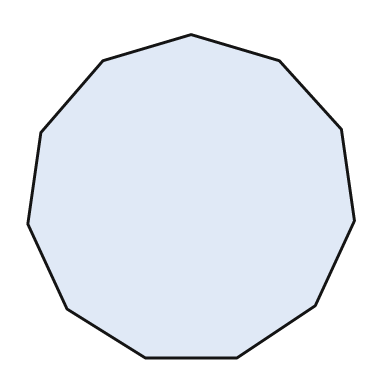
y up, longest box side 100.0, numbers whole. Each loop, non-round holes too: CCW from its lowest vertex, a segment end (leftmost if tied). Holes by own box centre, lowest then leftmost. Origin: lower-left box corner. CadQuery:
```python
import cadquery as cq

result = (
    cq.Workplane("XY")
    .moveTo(36.0, 0.0)
    .lineTo(64.0, 0.0)
    .lineTo(88.0, 16.0)
    .lineTo(100.0, 42.0)
    .lineTo(96.0, 70.0)
    .lineTo(77.0, 91.0)
    .lineTo(50.0, 99.0)
    .lineTo(23.0, 91.0)
    .lineTo(4.0, 69.0)
    .lineTo(0.0, 41.0)
    .lineTo(12.0, 15.0)
    .close()
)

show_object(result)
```